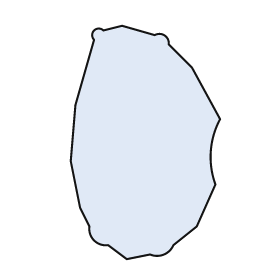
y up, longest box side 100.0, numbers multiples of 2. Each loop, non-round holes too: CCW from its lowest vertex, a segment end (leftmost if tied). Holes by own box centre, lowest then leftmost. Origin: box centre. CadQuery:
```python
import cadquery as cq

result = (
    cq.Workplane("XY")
    .moveTo(-8.0, -50.0)
    .lineTo(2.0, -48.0)
    .threePointArc((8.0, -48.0), (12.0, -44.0))
    .lineTo(22.0, -36.0)
    .lineTo(30.0, -18.0)
    .threePointArc((28.0, -4.0), (32.0, 10.0))
    .lineTo(20.0, 32.0)
    .lineTo(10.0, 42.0)
    .threePointArc((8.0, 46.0), (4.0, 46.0))
    .lineTo(-10.0, 50.0)
    .lineTo(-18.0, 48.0)
    .threePointArc((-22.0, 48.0), (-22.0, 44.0))
    .lineTo(-30.0, 16.0)
    .lineTo(-32.0, -8.0)
    .lineTo(-28.0, -28.0)
    .lineTo(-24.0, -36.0)
    .threePointArc((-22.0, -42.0), (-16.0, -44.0))
    .close()
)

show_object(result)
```